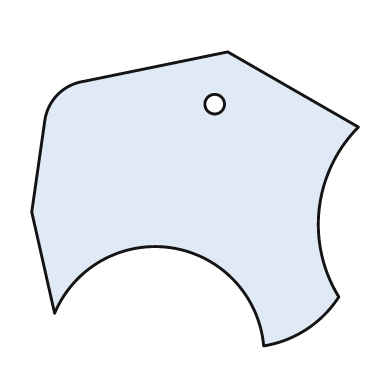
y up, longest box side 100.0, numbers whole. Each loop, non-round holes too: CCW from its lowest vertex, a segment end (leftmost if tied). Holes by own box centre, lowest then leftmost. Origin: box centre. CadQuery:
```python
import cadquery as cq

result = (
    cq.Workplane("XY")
    .moveTo(21.0, -45.0)
    .threePointArc((34.0, -40.0), (44.0, -30.0))
    .threePointArc((38.0, -3.0), (50.0, 22.0))
    .lineTo(10.0, 45.0)
    .lineTo(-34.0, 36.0)
    .threePointArc((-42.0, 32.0), (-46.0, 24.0))
    .lineTo(-50.0, -4.0)
    .lineTo(-43.0, -35.0)
    .threePointArc((-7.0, -15.0), (21.0, -45.0))
    .close()
    .moveTo(6.0, 29.0)
    .circle(3.0)
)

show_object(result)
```